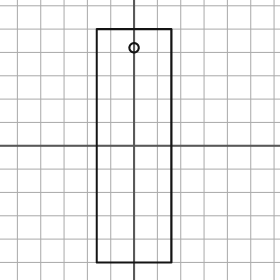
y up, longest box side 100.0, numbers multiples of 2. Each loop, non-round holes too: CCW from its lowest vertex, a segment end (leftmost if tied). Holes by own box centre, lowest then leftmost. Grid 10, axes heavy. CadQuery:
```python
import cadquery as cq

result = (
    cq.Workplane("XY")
    .moveTo(-16.0, -50.0)
    .lineTo(16.0, -50.0)
    .lineTo(16.0, 50.0)
    .lineTo(-16.0, 50.0)
    .close()
    .moveTo(0.0, 42.0)
    .circle(2.0)
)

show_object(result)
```